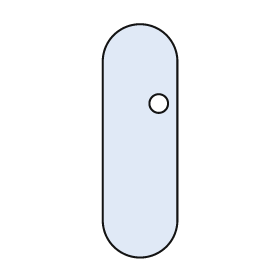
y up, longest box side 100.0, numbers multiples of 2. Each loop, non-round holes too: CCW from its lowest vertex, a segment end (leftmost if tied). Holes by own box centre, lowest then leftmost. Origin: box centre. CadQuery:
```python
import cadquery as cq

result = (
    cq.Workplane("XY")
    .moveTo(-16.0, -34.0)
    .threePointArc((0.0, -50.0), (16.0, -34.0))
    .lineTo(16.0, 34.0)
    .threePointArc((0.0, 50.0), (-16.0, 34.0))
    .close()
    .moveTo(8.0, 16.0)
    .circle(4.0)
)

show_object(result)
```